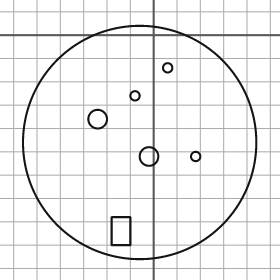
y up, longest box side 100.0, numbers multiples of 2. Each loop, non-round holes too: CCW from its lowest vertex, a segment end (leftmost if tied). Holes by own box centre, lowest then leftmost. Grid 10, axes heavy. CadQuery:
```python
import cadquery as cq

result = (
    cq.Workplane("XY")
    .moveTo(-6.0, -46.0)
    .circle(50.0)
    .moveTo(-18.0, -90.0)
    .lineTo(-10.0, -90.0)
    .lineTo(-10.0, -78.0)
    .lineTo(-18.0, -78.0)
    .close()
    .moveTo(-2.0, -52.0)
    .circle(4.0)
    .moveTo(18.0, -52.0)
    .circle(2.0)
    .moveTo(-24.0, -36.0)
    .circle(4.0)
    .moveTo(-8.0, -26.0)
    .circle(2.0)
    .moveTo(6.0, -14.0)
    .circle(2.0)
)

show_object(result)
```